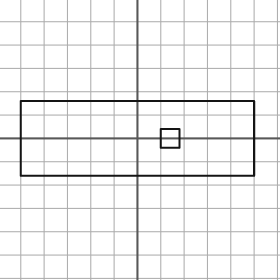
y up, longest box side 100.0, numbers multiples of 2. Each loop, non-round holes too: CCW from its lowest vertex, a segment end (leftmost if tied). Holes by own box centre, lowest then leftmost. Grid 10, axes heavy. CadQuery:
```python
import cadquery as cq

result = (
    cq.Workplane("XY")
    .moveTo(-50.0, -16.0)
    .lineTo(50.0, -16.0)
    .lineTo(50.0, 16.0)
    .lineTo(-50.0, 16.0)
    .close()
    .moveTo(10.0, -4.0)
    .lineTo(18.0, -4.0)
    .lineTo(18.0, 4.0)
    .lineTo(10.0, 4.0)
    .close()
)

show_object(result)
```